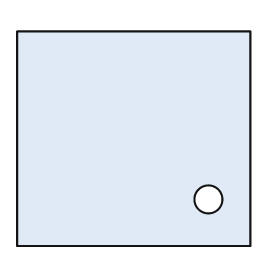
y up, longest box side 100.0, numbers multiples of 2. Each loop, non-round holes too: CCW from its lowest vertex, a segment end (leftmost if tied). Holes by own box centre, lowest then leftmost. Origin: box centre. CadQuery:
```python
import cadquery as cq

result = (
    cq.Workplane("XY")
    .moveTo(-50.0, -46.0)
    .lineTo(50.0, -46.0)
    .lineTo(50.0, 46.0)
    .lineTo(-50.0, 46.0)
    .close()
    .moveTo(32.0, -26.0)
    .circle(6.0)
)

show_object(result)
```